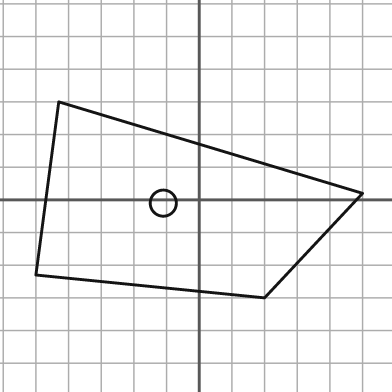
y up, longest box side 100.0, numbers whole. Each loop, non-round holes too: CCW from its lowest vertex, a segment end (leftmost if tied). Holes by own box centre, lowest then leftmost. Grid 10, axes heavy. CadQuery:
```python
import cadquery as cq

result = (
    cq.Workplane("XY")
    .moveTo(20.0, -30.0)
    .lineTo(50.0, 2.0)
    .lineTo(-43.0, 30.0)
    .lineTo(-50.0, -23.0)
    .close()
    .moveTo(-11.0, -1.0)
    .circle(4.0)
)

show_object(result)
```